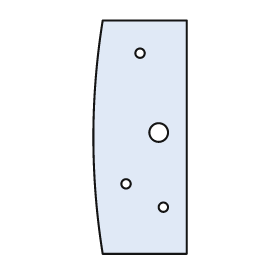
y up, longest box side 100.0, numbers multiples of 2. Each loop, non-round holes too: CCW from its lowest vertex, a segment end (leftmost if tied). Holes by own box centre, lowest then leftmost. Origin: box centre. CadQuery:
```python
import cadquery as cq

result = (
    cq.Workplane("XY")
    .moveTo(-16.0, -50.0)
    .lineTo(20.0, -50.0)
    .lineTo(20.0, 50.0)
    .lineTo(-16.0, 50.0)
    .threePointArc((-20.0, 0.0), (-16.0, -50.0))
    .close()
    .moveTo(10.0, -30.0)
    .circle(2.0)
    .moveTo(-6.0, -20.0)
    .circle(2.0)
    .moveTo(8.0, 2.0)
    .circle(4.0)
    .moveTo(0.0, 36.0)
    .circle(2.0)
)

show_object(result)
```